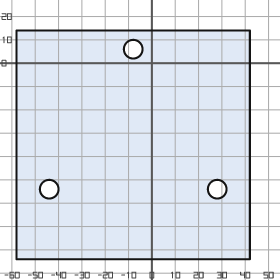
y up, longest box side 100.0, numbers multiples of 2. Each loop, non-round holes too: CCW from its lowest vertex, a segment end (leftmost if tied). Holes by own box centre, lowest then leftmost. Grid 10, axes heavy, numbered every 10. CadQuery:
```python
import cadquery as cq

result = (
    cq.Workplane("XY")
    .moveTo(-58.0, -84.0)
    .lineTo(42.0, -84.0)
    .lineTo(42.0, 14.0)
    .lineTo(-58.0, 14.0)
    .close()
    .moveTo(-44.0, -54.0)
    .circle(4.0)
    .moveTo(28.0, -54.0)
    .circle(4.0)
    .moveTo(-8.0, 6.0)
    .circle(4.0)
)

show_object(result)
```